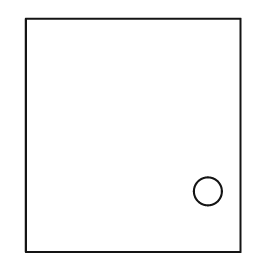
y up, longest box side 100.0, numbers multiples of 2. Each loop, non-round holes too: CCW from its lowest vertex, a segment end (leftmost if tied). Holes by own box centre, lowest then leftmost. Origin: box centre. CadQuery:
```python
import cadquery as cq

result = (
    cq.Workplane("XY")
    .moveTo(-46.0, -50.0)
    .lineTo(46.0, -50.0)
    .lineTo(46.0, 50.0)
    .lineTo(-46.0, 50.0)
    .close()
    .moveTo(32.0, -24.0)
    .circle(6.0)
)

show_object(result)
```